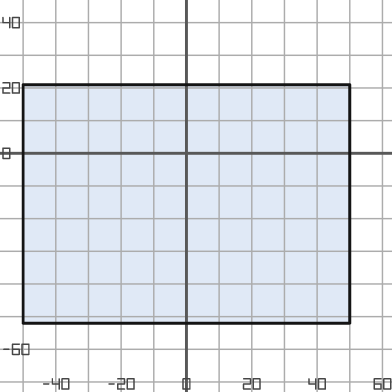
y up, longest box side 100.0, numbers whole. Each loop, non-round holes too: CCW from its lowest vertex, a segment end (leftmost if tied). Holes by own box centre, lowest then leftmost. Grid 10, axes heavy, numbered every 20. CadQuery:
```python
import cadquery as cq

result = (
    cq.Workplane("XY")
    .moveTo(-50.0, -52.0)
    .lineTo(50.0, -52.0)
    .lineTo(50.0, 21.0)
    .lineTo(-50.0, 21.0)
    .close()
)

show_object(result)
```